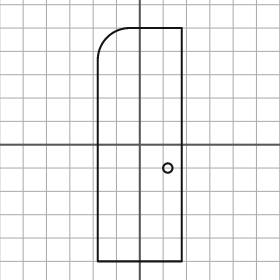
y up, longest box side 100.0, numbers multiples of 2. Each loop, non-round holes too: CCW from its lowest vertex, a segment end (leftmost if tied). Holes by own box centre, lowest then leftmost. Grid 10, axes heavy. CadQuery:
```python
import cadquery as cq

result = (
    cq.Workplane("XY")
    .moveTo(-18.0, -50.0)
    .lineTo(18.0, -50.0)
    .lineTo(18.0, 50.0)
    .lineTo(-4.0, 50.0)
    .threePointArc((-14.0, 46.0), (-18.0, 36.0))
    .close()
    .moveTo(12.0, -10.0)
    .circle(2.0)
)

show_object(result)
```